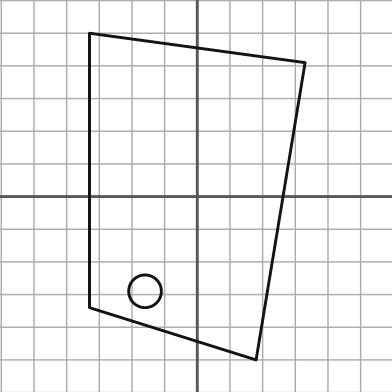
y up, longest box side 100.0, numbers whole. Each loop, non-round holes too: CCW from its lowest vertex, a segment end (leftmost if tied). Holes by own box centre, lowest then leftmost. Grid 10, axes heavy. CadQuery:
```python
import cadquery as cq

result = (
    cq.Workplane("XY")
    .moveTo(18.0, -50.0)
    .lineTo(33.0, 41.0)
    .lineTo(-33.0, 50.0)
    .lineTo(-33.0, -34.0)
    .close()
    .moveTo(-16.0, -29.0)
    .circle(5.0)
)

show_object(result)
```